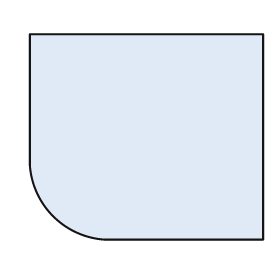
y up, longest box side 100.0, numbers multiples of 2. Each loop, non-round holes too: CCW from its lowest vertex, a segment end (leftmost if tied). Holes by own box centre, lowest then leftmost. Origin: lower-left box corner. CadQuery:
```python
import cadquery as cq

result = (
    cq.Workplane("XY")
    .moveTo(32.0, 0.0)
    .lineTo(100.0, 0.0)
    .lineTo(100.0, 88.0)
    .lineTo(0.0, 88.0)
    .lineTo(0.0, 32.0)
    .threePointArc((10.0, 10.0), (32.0, 0.0))
    .close()
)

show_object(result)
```